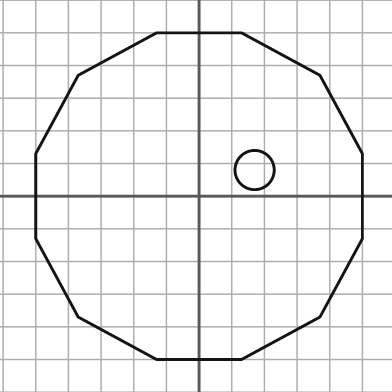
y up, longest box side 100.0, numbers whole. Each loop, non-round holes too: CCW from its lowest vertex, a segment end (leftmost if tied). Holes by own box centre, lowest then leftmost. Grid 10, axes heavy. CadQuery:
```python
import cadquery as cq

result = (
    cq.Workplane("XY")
    .moveTo(-13.0, -50.0)
    .lineTo(13.0, -50.0)
    .lineTo(37.0, -37.0)
    .lineTo(50.0, -13.0)
    .lineTo(50.0, 13.0)
    .lineTo(37.0, 37.0)
    .lineTo(13.0, 50.0)
    .lineTo(-13.0, 50.0)
    .lineTo(-37.0, 37.0)
    .lineTo(-50.0, 13.0)
    .lineTo(-50.0, -13.0)
    .lineTo(-37.0, -37.0)
    .close()
    .moveTo(17.0, 8.0)
    .circle(6.0)
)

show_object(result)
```